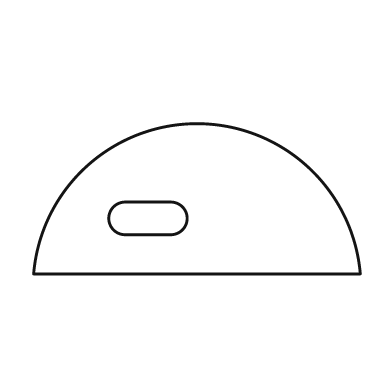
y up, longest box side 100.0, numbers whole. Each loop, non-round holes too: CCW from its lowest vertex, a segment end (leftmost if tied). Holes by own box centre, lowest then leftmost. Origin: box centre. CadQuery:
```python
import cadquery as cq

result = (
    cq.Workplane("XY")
    .moveTo(-50.0, -23.0)
    .lineTo(50.0, -23.0)
    .threePointArc((0.0, 23.0), (-50.0, -23.0))
    .close()
    .moveTo(-22.0, -11.0)
    .lineTo(-8.0, -11.0)
    .threePointArc((-3.0, -6.0), (-8.0, -1.0))
    .lineTo(-22.0, -1.0)
    .threePointArc((-27.0, -6.0), (-22.0, -11.0))
    .close()
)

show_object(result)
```